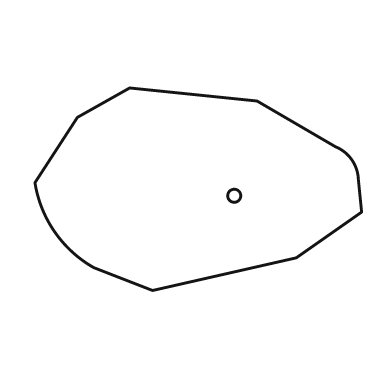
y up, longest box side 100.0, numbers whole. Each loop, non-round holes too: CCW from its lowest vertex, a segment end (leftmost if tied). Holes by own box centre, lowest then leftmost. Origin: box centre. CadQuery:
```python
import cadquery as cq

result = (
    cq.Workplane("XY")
    .moveTo(-14.0, -31.0)
    .lineTo(30.0, -21.0)
    .lineTo(50.0, -7.0)
    .lineTo(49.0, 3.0)
    .threePointArc((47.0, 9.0), (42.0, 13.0))
    .lineTo(18.0, 27.0)
    .lineTo(-21.0, 31.0)
    .lineTo(-37.0, 22.0)
    .lineTo(-50.0, 2.0)
    .threePointArc((-44.0, -13.0), (-32.0, -24.0))
    .close()
    .moveTo(11.0, -2.0)
    .circle(2.0)
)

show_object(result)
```